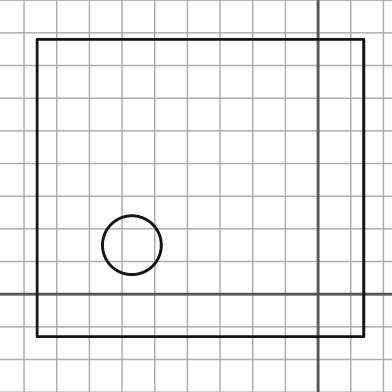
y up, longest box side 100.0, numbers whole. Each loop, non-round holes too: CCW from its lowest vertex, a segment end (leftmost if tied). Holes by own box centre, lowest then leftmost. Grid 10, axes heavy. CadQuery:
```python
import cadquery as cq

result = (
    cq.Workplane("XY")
    .moveTo(-86.0, -13.0)
    .lineTo(14.0, -13.0)
    .lineTo(14.0, 78.0)
    .lineTo(-86.0, 78.0)
    .close()
    .moveTo(-57.0, 15.0)
    .circle(9.0)
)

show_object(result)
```